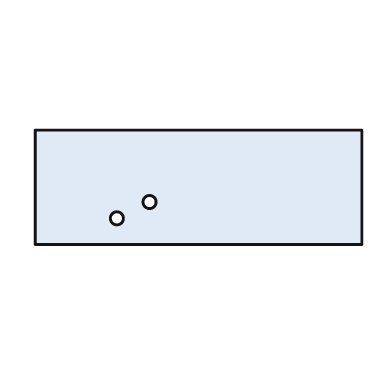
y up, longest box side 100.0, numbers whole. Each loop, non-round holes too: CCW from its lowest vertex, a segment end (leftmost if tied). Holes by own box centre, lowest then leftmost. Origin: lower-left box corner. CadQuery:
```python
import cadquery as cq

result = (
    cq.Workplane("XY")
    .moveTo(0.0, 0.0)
    .lineTo(100.0, 0.0)
    .lineTo(100.0, 35.0)
    .lineTo(0.0, 35.0)
    .close()
    .moveTo(25.0, 8.0)
    .circle(2.0)
    .moveTo(35.0, 13.0)
    .circle(2.0)
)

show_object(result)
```